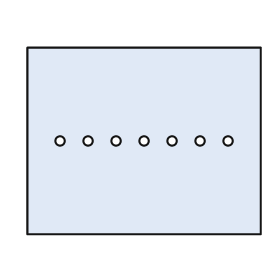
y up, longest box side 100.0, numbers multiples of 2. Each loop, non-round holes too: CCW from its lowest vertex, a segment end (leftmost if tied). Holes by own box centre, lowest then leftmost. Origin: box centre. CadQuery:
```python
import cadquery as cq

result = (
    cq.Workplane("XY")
    .moveTo(-50.0, -40.0)
    .lineTo(50.0, -40.0)
    .lineTo(50.0, 40.0)
    .lineTo(-50.0, 40.0)
    .close()
    .moveTo(-36.0, 0.0)
    .circle(2.0)
    .moveTo(-24.0, 0.0)
    .circle(2.0)
    .moveTo(-12.0, 0.0)
    .circle(2.0)
    .moveTo(0.0, 0.0)
    .circle(2.0)
    .moveTo(12.0, 0.0)
    .circle(2.0)
    .moveTo(24.0, 0.0)
    .circle(2.0)
    .moveTo(36.0, 0.0)
    .circle(2.0)
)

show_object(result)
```